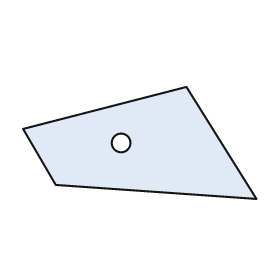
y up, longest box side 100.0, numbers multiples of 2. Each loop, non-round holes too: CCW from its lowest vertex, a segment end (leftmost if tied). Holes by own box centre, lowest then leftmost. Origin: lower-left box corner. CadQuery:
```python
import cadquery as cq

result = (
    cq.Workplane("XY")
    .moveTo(100.0, 0.0)
    .lineTo(70.0, 48.0)
    .lineTo(0.0, 30.0)
    .lineTo(14.0, 6.0)
    .close()
    .moveTo(42.0, 24.0)
    .circle(4.0)
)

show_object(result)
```